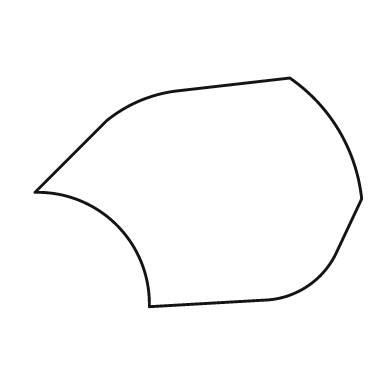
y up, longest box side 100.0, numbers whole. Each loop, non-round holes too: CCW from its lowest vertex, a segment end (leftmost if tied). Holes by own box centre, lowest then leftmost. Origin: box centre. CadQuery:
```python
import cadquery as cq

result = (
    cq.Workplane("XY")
    .moveTo(-15.0, -35.0)
    .lineTo(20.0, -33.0)
    .threePointArc((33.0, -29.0), (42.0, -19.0))
    .lineTo(50.0, -2.0)
    .threePointArc((43.0, 19.0), (28.0, 35.0))
    .lineTo(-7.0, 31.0)
    .threePointArc((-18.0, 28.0), (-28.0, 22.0))
    .lineTo(-50.0, 0.0)
    .threePointArc((-25.0, -10.0), (-15.0, -35.0))
    .close()
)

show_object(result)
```